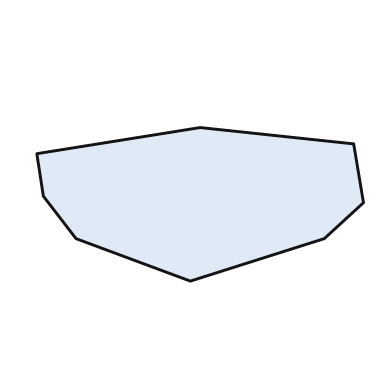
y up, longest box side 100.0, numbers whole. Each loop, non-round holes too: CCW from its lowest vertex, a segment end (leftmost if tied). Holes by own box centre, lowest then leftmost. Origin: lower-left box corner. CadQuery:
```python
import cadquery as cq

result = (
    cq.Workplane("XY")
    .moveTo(47.0, 0.0)
    .lineTo(88.0, 13.0)
    .lineTo(100.0, 24.0)
    .lineTo(97.0, 42.0)
    .lineTo(50.0, 47.0)
    .lineTo(0.0, 39.0)
    .lineTo(2.0, 26.0)
    .lineTo(12.0, 13.0)
    .close()
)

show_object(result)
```